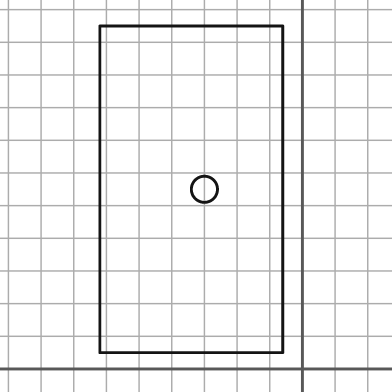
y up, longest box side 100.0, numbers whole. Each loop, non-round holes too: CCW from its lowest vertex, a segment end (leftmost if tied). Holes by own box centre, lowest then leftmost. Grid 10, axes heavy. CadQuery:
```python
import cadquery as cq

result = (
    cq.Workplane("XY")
    .moveTo(-62.0, 5.0)
    .lineTo(-6.0, 5.0)
    .lineTo(-6.0, 105.0)
    .lineTo(-62.0, 105.0)
    .close()
    .moveTo(-30.0, 55.0)
    .circle(4.0)
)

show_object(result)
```